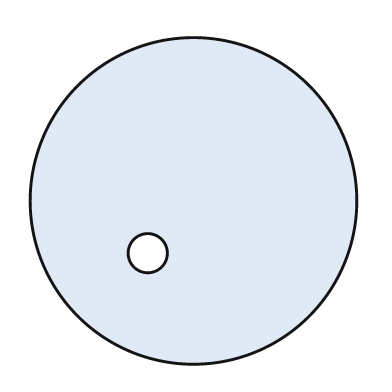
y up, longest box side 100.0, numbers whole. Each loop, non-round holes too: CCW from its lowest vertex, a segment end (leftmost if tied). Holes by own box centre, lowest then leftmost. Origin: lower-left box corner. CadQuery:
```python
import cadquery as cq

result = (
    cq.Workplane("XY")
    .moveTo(50.0, 50.0)
    .circle(50.0)
    .moveTo(36.0, 34.0)
    .circle(6.0)
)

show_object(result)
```